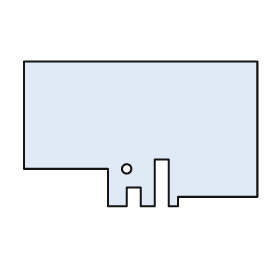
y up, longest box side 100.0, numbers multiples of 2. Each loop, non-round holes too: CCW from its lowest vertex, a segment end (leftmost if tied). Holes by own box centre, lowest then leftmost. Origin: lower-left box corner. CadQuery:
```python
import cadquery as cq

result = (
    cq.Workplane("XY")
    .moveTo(36.0, 0.0)
    .lineTo(44.0, 0.0)
    .lineTo(44.0, 8.0)
    .lineTo(50.0, 8.0)
    .lineTo(50.0, 0.0)
    .lineTo(56.0, 0.0)
    .lineTo(56.0, 20.0)
    .lineTo(62.0, 20.0)
    .lineTo(62.0, 0.0)
    .lineTo(66.0, 0.0)
    .lineTo(66.0, 4.0)
    .lineTo(100.0, 4.0)
    .lineTo(100.0, 62.0)
    .lineTo(0.0, 62.0)
    .lineTo(0.0, 16.0)
    .lineTo(36.0, 16.0)
    .close()
    .moveTo(44.0, 16.0)
    .circle(2.0)
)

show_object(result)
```